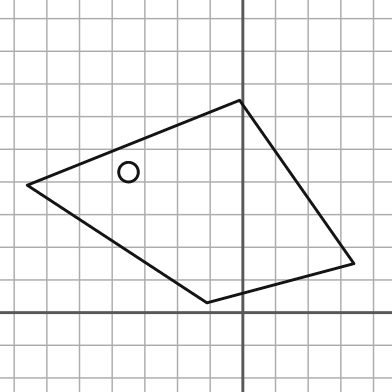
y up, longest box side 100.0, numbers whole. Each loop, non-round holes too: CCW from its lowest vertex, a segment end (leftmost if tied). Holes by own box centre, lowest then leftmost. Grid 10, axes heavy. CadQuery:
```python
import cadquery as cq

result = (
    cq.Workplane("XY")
    .moveTo(-11.0, 3.0)
    .lineTo(34.0, 15.0)
    .lineTo(-1.0, 65.0)
    .lineTo(-66.0, 39.0)
    .close()
    .moveTo(-35.0, 43.0)
    .circle(3.0)
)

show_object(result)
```